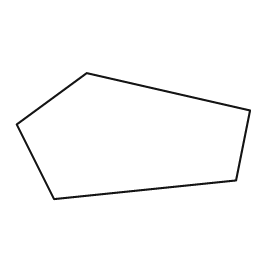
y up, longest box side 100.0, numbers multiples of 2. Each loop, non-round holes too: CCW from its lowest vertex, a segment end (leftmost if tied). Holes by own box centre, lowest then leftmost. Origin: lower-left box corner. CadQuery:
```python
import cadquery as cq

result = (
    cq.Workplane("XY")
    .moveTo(16.0, 0.0)
    .lineTo(94.0, 8.0)
    .lineTo(100.0, 38.0)
    .lineTo(30.0, 54.0)
    .lineTo(0.0, 32.0)
    .close()
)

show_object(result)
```